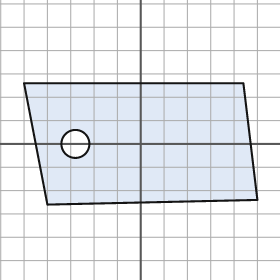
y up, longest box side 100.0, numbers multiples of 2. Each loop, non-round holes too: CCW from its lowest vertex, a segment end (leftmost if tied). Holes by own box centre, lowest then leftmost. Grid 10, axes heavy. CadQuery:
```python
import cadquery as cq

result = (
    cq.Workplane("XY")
    .moveTo(-40.0, -26.0)
    .lineTo(50.0, -24.0)
    .lineTo(44.0, 26.0)
    .lineTo(-50.0, 26.0)
    .close()
    .moveTo(-28.0, 0.0)
    .circle(6.0)
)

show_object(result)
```